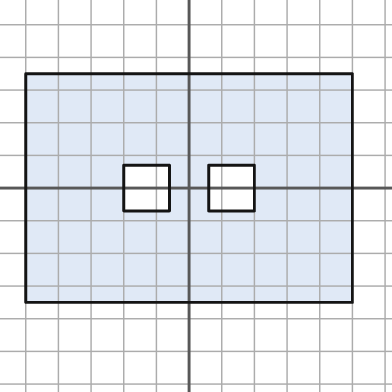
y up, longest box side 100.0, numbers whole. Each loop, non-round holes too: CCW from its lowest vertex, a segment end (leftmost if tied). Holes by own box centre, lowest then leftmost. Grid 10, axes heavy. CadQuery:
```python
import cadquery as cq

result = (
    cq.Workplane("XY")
    .moveTo(-50.0, -35.0)
    .lineTo(50.0, -35.0)
    .lineTo(50.0, 35.0)
    .lineTo(-50.0, 35.0)
    .close()
    .moveTo(-20.0, -7.0)
    .lineTo(-6.0, -7.0)
    .lineTo(-6.0, 7.0)
    .lineTo(-20.0, 7.0)
    .close()
    .moveTo(6.0, -7.0)
    .lineTo(20.0, -7.0)
    .lineTo(20.0, 7.0)
    .lineTo(6.0, 7.0)
    .close()
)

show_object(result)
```